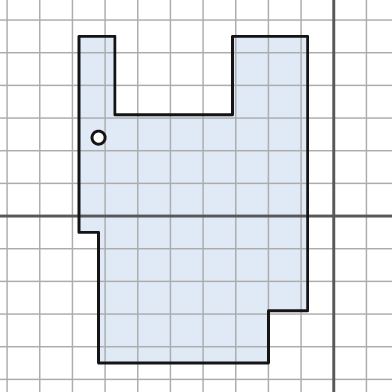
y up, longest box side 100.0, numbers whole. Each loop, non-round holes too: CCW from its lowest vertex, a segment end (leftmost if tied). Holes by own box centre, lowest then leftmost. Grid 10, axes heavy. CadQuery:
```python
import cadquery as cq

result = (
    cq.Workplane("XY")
    .moveTo(-72.0, -45.0)
    .lineTo(-20.0, -45.0)
    .lineTo(-20.0, -29.0)
    .lineTo(-8.0, -29.0)
    .lineTo(-8.0, 55.0)
    .lineTo(-31.0, 55.0)
    .lineTo(-31.0, 31.0)
    .lineTo(-67.0, 31.0)
    .lineTo(-67.0, 55.0)
    .lineTo(-78.0, 55.0)
    .lineTo(-78.0, -5.0)
    .lineTo(-72.0, -5.0)
    .close()
    .moveTo(-72.0, 24.0)
    .circle(2.0)
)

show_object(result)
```